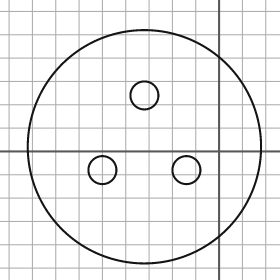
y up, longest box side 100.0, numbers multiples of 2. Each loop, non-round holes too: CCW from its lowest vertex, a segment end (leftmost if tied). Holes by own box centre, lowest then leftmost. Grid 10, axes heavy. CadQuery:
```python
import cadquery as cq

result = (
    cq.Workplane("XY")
    .moveTo(-32.0, 2.0)
    .circle(50.0)
    .moveTo(-50.0, -8.0)
    .circle(6.0)
    .moveTo(-14.0, -8.0)
    .circle(6.0)
    .moveTo(-32.0, 24.0)
    .circle(6.0)
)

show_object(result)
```